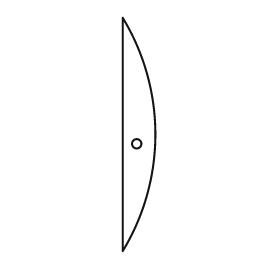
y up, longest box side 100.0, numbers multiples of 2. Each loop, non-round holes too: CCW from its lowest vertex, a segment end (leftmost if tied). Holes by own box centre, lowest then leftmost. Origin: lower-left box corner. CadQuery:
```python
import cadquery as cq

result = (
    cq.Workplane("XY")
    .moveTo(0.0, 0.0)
    .threePointArc((14.0, 50.0), (0.0, 100.0))
    .close()
    .moveTo(6.0, 46.0)
    .circle(2.0)
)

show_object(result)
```